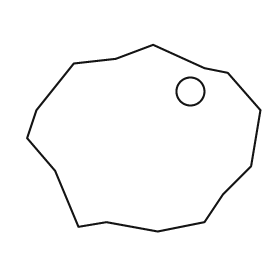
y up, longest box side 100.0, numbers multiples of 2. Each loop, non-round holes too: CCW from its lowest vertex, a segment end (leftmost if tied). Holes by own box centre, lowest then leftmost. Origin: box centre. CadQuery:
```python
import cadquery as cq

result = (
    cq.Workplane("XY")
    .moveTo(6.0, -40.0)
    .lineTo(26.0, -36.0)
    .lineTo(34.0, -24.0)
    .lineTo(46.0, -12.0)
    .lineTo(50.0, 12.0)
    .lineTo(36.0, 28.0)
    .lineTo(26.0, 30.0)
    .lineTo(4.0, 40.0)
    .lineTo(-12.0, 34.0)
    .lineTo(-30.0, 32.0)
    .lineTo(-46.0, 12.0)
    .lineTo(-50.0, 0.0)
    .lineTo(-38.0, -14.0)
    .lineTo(-28.0, -38.0)
    .lineTo(-16.0, -36.0)
    .close()
    .moveTo(20.0, 20.0)
    .circle(6.0)
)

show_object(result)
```